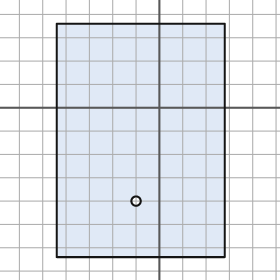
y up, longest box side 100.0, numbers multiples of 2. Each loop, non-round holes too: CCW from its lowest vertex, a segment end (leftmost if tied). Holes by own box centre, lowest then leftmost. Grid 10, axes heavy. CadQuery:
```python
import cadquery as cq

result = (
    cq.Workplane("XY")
    .moveTo(-44.0, -64.0)
    .lineTo(28.0, -64.0)
    .lineTo(28.0, 36.0)
    .lineTo(-44.0, 36.0)
    .close()
    .moveTo(-10.0, -40.0)
    .circle(2.0)
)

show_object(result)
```